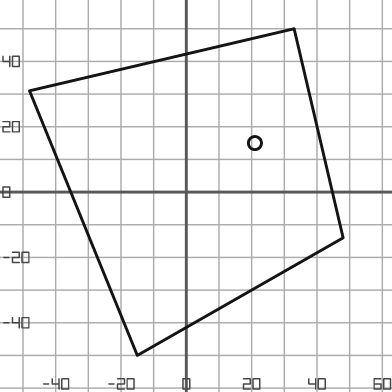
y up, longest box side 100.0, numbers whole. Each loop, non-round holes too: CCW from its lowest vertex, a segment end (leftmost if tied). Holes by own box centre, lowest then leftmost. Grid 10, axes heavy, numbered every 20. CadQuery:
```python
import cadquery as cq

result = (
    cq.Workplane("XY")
    .moveTo(-15.0, -50.0)
    .lineTo(48.0, -14.0)
    .lineTo(33.0, 50.0)
    .lineTo(-48.0, 31.0)
    .close()
    .moveTo(21.0, 15.0)
    .circle(2.0)
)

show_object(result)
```